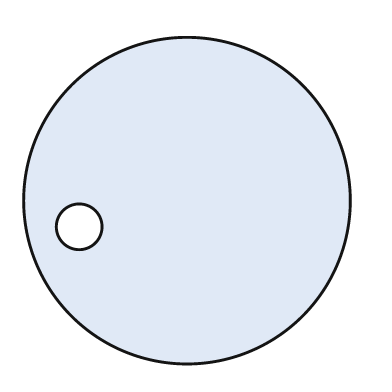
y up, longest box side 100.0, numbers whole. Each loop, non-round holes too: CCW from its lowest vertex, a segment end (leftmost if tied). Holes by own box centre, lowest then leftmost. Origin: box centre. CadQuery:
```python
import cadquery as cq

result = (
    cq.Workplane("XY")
    .moveTo(0.0, 0.0)
    .circle(50.0)
    .moveTo(-33.0, -8.0)
    .circle(7.0)
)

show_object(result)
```